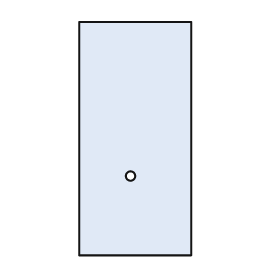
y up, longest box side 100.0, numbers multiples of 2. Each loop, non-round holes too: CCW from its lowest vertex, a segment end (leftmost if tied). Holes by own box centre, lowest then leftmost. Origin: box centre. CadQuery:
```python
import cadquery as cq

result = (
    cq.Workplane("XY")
    .moveTo(-24.0, -50.0)
    .lineTo(24.0, -50.0)
    .lineTo(24.0, 50.0)
    .lineTo(-24.0, 50.0)
    .close()
    .moveTo(-2.0, -16.0)
    .circle(2.0)
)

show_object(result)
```